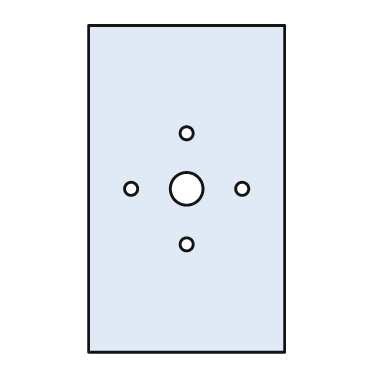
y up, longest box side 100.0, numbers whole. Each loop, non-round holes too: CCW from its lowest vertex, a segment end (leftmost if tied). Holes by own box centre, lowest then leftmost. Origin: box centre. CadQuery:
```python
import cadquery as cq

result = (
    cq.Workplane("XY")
    .moveTo(-30.0, -50.0)
    .lineTo(30.0, -50.0)
    .lineTo(30.0, 50.0)
    .lineTo(-30.0, 50.0)
    .close()
    .moveTo(0.0, -17.0)
    .circle(2.0)
    .moveTo(-17.0, 0.0)
    .circle(2.0)
    .moveTo(0.0, 0.0)
    .circle(5.0)
    .moveTo(17.0, 0.0)
    .circle(2.0)
    .moveTo(0.0, 17.0)
    .circle(2.0)
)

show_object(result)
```